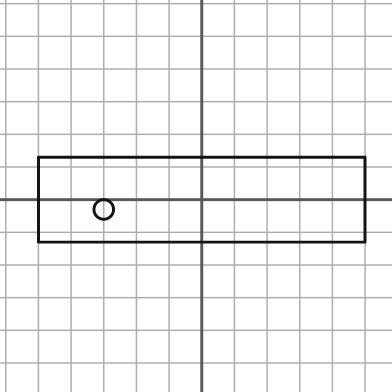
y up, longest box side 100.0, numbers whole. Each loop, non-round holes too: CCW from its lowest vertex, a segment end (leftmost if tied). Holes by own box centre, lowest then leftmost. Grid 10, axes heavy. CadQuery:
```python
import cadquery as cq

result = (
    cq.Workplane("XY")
    .moveTo(-50.0, -13.0)
    .lineTo(50.0, -13.0)
    .lineTo(50.0, 13.0)
    .lineTo(-50.0, 13.0)
    .close()
    .moveTo(-30.0, -3.0)
    .circle(3.0)
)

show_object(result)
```